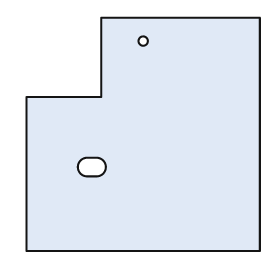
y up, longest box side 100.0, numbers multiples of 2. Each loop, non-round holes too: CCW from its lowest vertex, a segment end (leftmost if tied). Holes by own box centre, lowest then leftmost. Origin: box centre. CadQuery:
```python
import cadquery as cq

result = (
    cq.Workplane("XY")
    .moveTo(-50.0, -50.0)
    .lineTo(50.0, -50.0)
    .lineTo(50.0, 50.0)
    .lineTo(-18.0, 50.0)
    .lineTo(-18.0, 16.0)
    .lineTo(-50.0, 16.0)
    .close()
    .moveTo(-24.0, -18.0)
    .lineTo(-20.0, -18.0)
    .threePointArc((-16.0, -14.0), (-20.0, -10.0))
    .lineTo(-24.0, -10.0)
    .threePointArc((-28.0, -14.0), (-24.0, -18.0))
    .close()
    .moveTo(0.0, 40.0)
    .circle(2.0)
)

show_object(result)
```